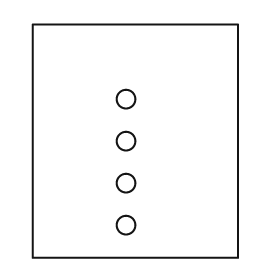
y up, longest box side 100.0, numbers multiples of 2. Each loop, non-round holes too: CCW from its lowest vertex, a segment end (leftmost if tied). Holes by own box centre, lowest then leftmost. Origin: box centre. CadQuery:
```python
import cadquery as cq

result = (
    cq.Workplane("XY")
    .moveTo(-44.0, -50.0)
    .lineTo(44.0, -50.0)
    .lineTo(44.0, 50.0)
    .lineTo(-44.0, 50.0)
    .close()
    .moveTo(-4.0, -36.0)
    .circle(4.0)
    .moveTo(-4.0, -18.0)
    .circle(4.0)
    .moveTo(-4.0, 0.0)
    .circle(4.0)
    .moveTo(-4.0, 18.0)
    .circle(4.0)
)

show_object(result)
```